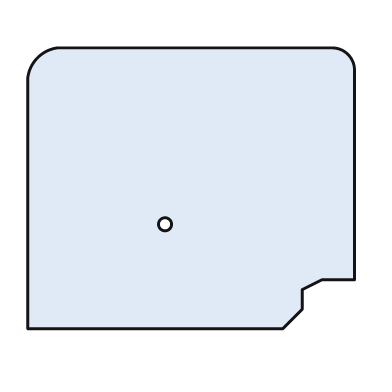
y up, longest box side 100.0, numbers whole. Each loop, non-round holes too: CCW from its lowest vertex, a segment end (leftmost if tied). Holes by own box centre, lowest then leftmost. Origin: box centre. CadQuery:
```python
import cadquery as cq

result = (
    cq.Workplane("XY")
    .moveTo(-50.0, -43.0)
    .lineTo(28.0, -43.0)
    .lineTo(34.0, -37.0)
    .lineTo(34.0, -31.0)
    .lineTo(40.0, -28.0)
    .lineTo(50.0, -28.0)
    .lineTo(50.0, 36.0)
    .threePointArc((48.0, 41.0), (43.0, 43.0))
    .lineTo(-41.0, 43.0)
    .threePointArc((-47.0, 40.0), (-50.0, 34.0))
    .close()
    .moveTo(-8.0, -11.0)
    .circle(2.0)
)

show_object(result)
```